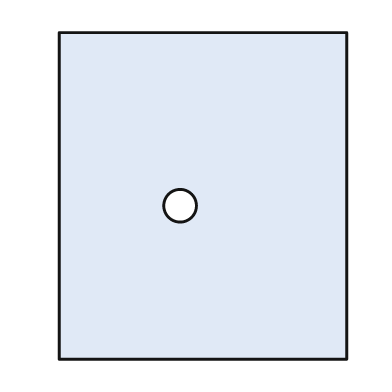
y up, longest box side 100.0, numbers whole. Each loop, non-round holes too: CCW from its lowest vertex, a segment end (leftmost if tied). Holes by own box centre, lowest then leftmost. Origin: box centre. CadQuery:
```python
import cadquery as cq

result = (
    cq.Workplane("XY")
    .moveTo(-44.0, -50.0)
    .lineTo(44.0, -50.0)
    .lineTo(44.0, 50.0)
    .lineTo(-44.0, 50.0)
    .close()
    .moveTo(-7.0, -3.0)
    .circle(5.0)
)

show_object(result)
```